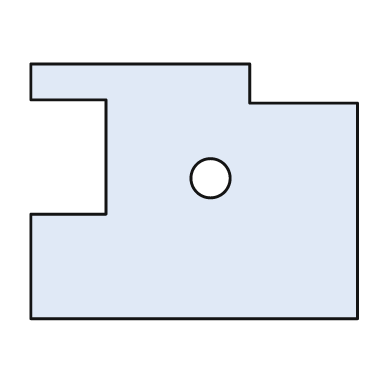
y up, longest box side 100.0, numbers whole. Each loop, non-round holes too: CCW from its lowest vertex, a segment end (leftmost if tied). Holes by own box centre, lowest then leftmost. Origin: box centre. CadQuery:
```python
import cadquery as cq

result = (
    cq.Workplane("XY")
    .moveTo(-50.0, -39.0)
    .lineTo(50.0, -39.0)
    .lineTo(50.0, 27.0)
    .lineTo(17.0, 27.0)
    .lineTo(17.0, 39.0)
    .lineTo(-50.0, 39.0)
    .lineTo(-50.0, 28.0)
    .lineTo(-27.0, 28.0)
    .lineTo(-27.0, -7.0)
    .lineTo(-50.0, -7.0)
    .close()
    .moveTo(5.0, 4.0)
    .circle(6.0)
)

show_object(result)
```